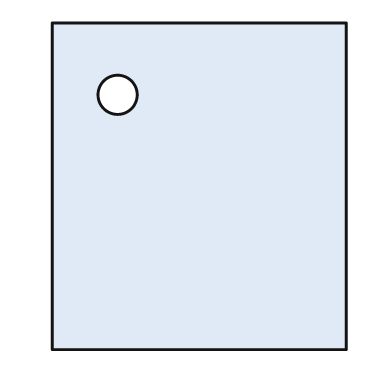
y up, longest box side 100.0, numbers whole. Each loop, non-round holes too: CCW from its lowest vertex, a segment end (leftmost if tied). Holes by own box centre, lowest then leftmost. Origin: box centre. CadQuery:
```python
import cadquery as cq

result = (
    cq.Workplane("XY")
    .moveTo(-45.0, -50.0)
    .lineTo(45.0, -50.0)
    .lineTo(45.0, 50.0)
    .lineTo(-45.0, 50.0)
    .close()
    .moveTo(-25.0, 28.0)
    .circle(6.0)
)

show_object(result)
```